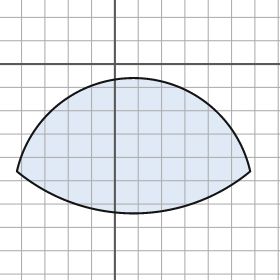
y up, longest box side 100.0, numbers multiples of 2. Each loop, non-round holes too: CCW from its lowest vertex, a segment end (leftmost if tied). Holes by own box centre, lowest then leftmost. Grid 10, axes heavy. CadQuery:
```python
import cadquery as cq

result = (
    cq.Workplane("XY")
    .moveTo(-42.0, -46.0)
    .threePointArc((8.0, -64.0), (58.0, -46.0))
    .threePointArc((8.0, -6.0), (-42.0, -46.0))
    .close()
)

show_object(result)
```